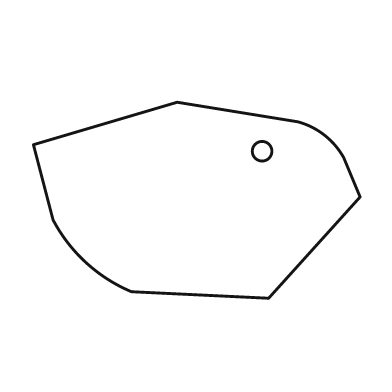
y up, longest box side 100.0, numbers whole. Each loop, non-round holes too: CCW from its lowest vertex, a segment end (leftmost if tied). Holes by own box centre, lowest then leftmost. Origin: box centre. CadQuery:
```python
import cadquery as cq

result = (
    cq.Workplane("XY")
    .moveTo(22.0, -30.0)
    .lineTo(50.0, 1.0)
    .lineTo(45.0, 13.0)
    .threePointArc((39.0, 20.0), (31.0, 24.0))
    .lineTo(-6.0, 30.0)
    .lineTo(-50.0, 17.0)
    .lineTo(-44.0, -6.0)
    .threePointArc((-34.0, -19.0), (-20.0, -28.0))
    .close()
    .moveTo(20.0, 15.0)
    .circle(3.0)
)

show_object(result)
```